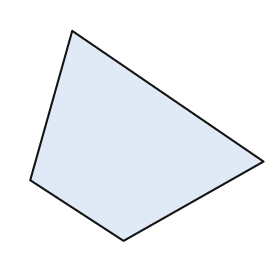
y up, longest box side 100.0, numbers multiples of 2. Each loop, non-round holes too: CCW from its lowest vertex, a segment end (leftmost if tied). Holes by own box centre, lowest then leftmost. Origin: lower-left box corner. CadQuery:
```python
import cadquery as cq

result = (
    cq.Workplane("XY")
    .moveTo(40.0, 0.0)
    .lineTo(100.0, 34.0)
    .lineTo(18.0, 90.0)
    .lineTo(0.0, 26.0)
    .close()
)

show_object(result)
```